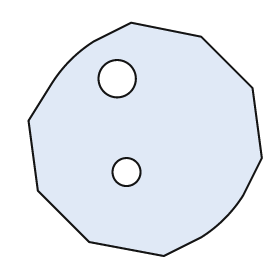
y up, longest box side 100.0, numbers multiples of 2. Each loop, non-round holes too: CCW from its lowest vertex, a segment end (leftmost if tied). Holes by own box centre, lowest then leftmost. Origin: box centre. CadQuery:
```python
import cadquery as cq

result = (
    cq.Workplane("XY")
    .moveTo(8.0, -50.0)
    .lineTo(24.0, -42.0)
    .threePointArc((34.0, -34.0), (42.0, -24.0))
    .lineTo(50.0, -8.0)
    .lineTo(46.0, 22.0)
    .lineTo(24.0, 44.0)
    .lineTo(-6.0, 50.0)
    .lineTo(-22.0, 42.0)
    .threePointArc((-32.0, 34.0), (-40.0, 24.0))
    .lineTo(-50.0, 8.0)
    .lineTo(-46.0, -22.0)
    .lineTo(-24.0, -44.0)
    .close()
    .moveTo(-8.0, -14.0)
    .circle(6.0)
    .moveTo(-12.0, 26.0)
    .circle(8.0)
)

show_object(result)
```